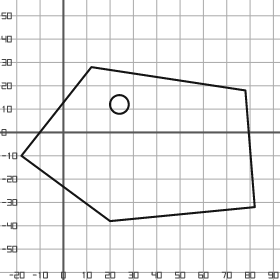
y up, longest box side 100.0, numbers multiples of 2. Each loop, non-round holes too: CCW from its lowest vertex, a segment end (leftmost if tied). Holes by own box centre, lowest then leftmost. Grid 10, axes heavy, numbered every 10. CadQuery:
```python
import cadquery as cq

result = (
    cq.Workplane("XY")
    .moveTo(20.0, -38.0)
    .lineTo(82.0, -32.0)
    .lineTo(78.0, 18.0)
    .lineTo(12.0, 28.0)
    .lineTo(-18.0, -10.0)
    .close()
    .moveTo(24.0, 12.0)
    .circle(4.0)
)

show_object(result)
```